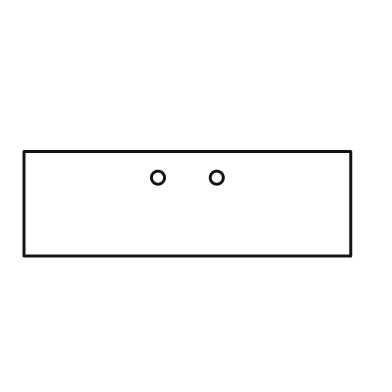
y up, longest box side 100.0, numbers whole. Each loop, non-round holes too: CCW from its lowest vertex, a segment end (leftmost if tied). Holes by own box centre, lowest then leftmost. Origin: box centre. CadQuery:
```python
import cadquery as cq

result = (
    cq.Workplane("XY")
    .moveTo(-50.0, -16.0)
    .lineTo(50.0, -16.0)
    .lineTo(50.0, 16.0)
    .lineTo(-50.0, 16.0)
    .close()
    .moveTo(-9.0, 8.0)
    .circle(2.0)
    .moveTo(9.0, 8.0)
    .circle(2.0)
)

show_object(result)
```